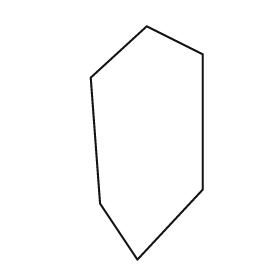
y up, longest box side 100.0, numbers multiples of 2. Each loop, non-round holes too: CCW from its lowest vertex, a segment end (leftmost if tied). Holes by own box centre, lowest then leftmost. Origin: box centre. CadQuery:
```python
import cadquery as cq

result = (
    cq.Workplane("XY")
    .moveTo(-4.0, -50.0)
    .lineTo(24.0, -20.0)
    .lineTo(24.0, 38.0)
    .lineTo(0.0, 50.0)
    .lineTo(-24.0, 28.0)
    .lineTo(-20.0, -26.0)
    .close()
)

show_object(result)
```